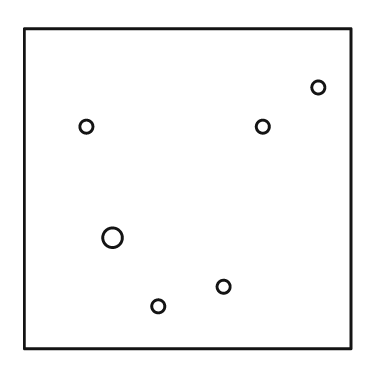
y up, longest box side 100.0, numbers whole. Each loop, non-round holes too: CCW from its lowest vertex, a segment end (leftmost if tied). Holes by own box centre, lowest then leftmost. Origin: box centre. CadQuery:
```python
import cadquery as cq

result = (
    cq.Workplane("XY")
    .moveTo(-50.0, -49.0)
    .lineTo(50.0, -49.0)
    .lineTo(50.0, 49.0)
    .lineTo(-50.0, 49.0)
    .close()
    .moveTo(-9.0, -36.0)
    .circle(2.0)
    .moveTo(11.0, -30.0)
    .circle(2.0)
    .moveTo(-23.0, -15.0)
    .circle(3.0)
    .moveTo(-31.0, 19.0)
    .circle(2.0)
    .moveTo(23.0, 19.0)
    .circle(2.0)
    .moveTo(40.0, 31.0)
    .circle(2.0)
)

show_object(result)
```